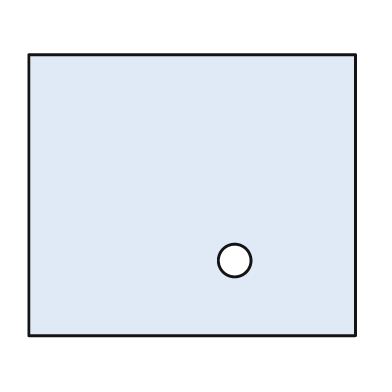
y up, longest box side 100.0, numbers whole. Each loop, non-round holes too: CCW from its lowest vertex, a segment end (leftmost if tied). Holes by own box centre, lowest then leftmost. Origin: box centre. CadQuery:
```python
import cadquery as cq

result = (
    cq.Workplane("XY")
    .moveTo(-50.0, -43.0)
    .lineTo(50.0, -43.0)
    .lineTo(50.0, 43.0)
    .lineTo(-50.0, 43.0)
    .close()
    .moveTo(13.0, -20.0)
    .circle(5.0)
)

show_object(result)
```